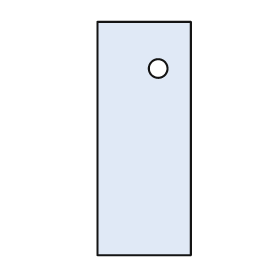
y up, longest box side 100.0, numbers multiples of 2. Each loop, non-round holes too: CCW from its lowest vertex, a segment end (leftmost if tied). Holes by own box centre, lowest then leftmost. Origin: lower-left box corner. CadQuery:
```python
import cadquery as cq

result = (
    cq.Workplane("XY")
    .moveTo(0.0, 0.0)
    .lineTo(40.0, 0.0)
    .lineTo(40.0, 100.0)
    .lineTo(0.0, 100.0)
    .close()
    .moveTo(26.0, 80.0)
    .circle(4.0)
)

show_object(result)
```